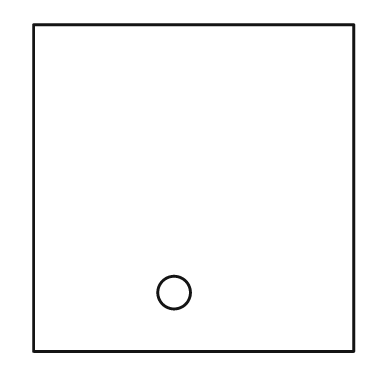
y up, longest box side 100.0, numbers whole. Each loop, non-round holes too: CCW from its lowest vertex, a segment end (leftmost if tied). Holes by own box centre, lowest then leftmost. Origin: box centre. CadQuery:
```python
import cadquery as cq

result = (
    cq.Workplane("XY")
    .moveTo(-49.0, -50.0)
    .lineTo(49.0, -50.0)
    .lineTo(49.0, 50.0)
    .lineTo(-49.0, 50.0)
    .close()
    .moveTo(-6.0, -32.0)
    .circle(5.0)
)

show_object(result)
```